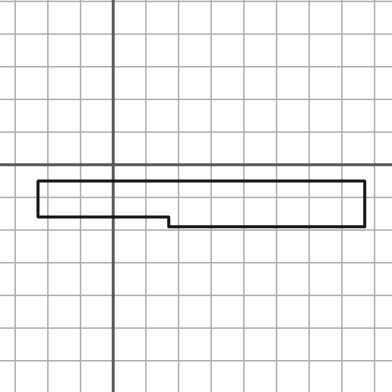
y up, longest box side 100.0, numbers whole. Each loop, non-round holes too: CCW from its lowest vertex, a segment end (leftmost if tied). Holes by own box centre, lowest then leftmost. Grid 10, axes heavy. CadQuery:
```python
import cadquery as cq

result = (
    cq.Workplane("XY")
    .moveTo(17.0, -19.0)
    .lineTo(77.0, -19.0)
    .lineTo(77.0, -5.0)
    .lineTo(-23.0, -5.0)
    .lineTo(-23.0, -16.0)
    .lineTo(17.0, -16.0)
    .close()
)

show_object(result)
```